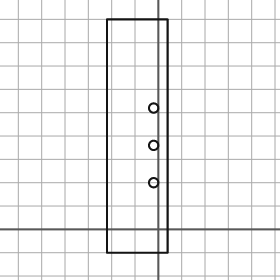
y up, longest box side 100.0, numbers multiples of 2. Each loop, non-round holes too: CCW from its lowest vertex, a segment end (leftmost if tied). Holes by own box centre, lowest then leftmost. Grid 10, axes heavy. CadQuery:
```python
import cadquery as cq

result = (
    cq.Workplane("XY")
    .moveTo(-22.0, -10.0)
    .lineTo(4.0, -10.0)
    .lineTo(4.0, 90.0)
    .lineTo(-22.0, 90.0)
    .close()
    .moveTo(-2.0, 20.0)
    .circle(2.0)
    .moveTo(-2.0, 36.0)
    .circle(2.0)
    .moveTo(-2.0, 52.0)
    .circle(2.0)
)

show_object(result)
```